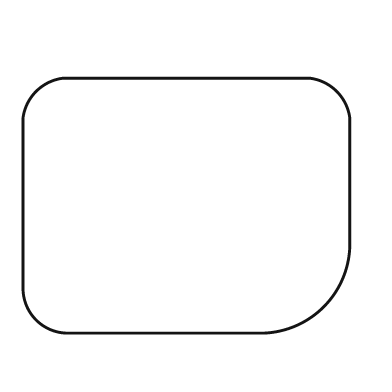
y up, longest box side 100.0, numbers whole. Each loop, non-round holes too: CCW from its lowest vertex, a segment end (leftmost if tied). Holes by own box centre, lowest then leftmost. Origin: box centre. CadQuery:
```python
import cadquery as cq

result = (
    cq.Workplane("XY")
    .moveTo(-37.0, -39.0)
    .lineTo(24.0, -39.0)
    .threePointArc((42.0, -31.0), (50.0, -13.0))
    .lineTo(50.0, 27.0)
    .threePointArc((46.0, 35.0), (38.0, 39.0))
    .lineTo(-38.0, 39.0)
    .threePointArc((-46.0, 35.0), (-50.0, 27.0))
    .lineTo(-50.0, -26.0)
    .threePointArc((-46.0, -35.0), (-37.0, -39.0))
    .close()
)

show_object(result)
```